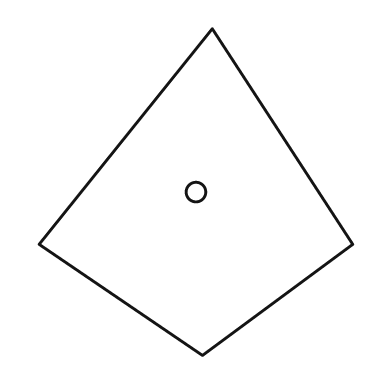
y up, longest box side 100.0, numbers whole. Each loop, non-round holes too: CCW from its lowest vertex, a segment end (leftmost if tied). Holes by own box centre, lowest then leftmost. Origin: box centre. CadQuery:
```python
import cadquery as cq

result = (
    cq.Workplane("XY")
    .moveTo(2.0, -50.0)
    .lineTo(48.0, -16.0)
    .lineTo(5.0, 50.0)
    .lineTo(-48.0, -16.0)
    .close()
    .moveTo(0.0, 0.0)
    .circle(3.0)
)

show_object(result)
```